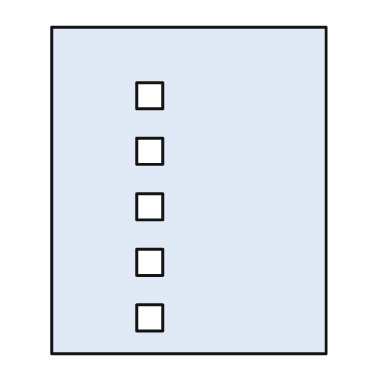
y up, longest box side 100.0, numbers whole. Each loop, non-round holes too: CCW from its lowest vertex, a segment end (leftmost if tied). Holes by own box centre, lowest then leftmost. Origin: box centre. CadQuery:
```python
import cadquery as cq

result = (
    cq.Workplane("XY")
    .moveTo(-42.0, -50.0)
    .lineTo(42.0, -50.0)
    .lineTo(42.0, 50.0)
    .lineTo(-42.0, 50.0)
    .close()
    .moveTo(-16.0, -43.0)
    .lineTo(-8.0, -43.0)
    .lineTo(-8.0, -35.0)
    .lineTo(-16.0, -35.0)
    .close()
    .moveTo(-16.0, -26.0)
    .lineTo(-8.0, -26.0)
    .lineTo(-8.0, -18.0)
    .lineTo(-16.0, -18.0)
    .close()
    .moveTo(-16.0, -9.0)
    .lineTo(-8.0, -9.0)
    .lineTo(-8.0, -1.0)
    .lineTo(-16.0, -1.0)
    .close()
    .moveTo(-16.0, 8.0)
    .lineTo(-8.0, 8.0)
    .lineTo(-8.0, 16.0)
    .lineTo(-16.0, 16.0)
    .close()
    .moveTo(-16.0, 25.0)
    .lineTo(-8.0, 25.0)
    .lineTo(-8.0, 33.0)
    .lineTo(-16.0, 33.0)
    .close()
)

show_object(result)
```